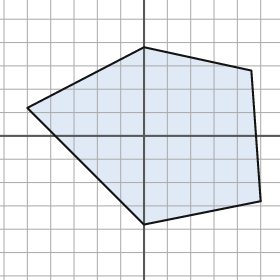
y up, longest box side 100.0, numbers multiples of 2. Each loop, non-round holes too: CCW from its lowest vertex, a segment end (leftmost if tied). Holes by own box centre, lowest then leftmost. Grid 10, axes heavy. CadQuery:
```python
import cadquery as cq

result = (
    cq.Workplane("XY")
    .moveTo(0.0, -38.0)
    .lineTo(50.0, -28.0)
    .lineTo(46.0, 28.0)
    .lineTo(0.0, 38.0)
    .lineTo(-50.0, 12.0)
    .close()
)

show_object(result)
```